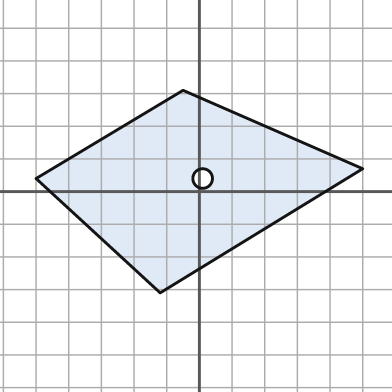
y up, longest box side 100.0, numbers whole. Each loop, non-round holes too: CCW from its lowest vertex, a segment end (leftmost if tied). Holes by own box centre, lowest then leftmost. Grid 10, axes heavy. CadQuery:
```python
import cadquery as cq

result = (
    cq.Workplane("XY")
    .moveTo(-12.0, -31.0)
    .lineTo(50.0, 7.0)
    .lineTo(-5.0, 31.0)
    .lineTo(-50.0, 4.0)
    .close()
    .moveTo(1.0, 4.0)
    .circle(3.0)
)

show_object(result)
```